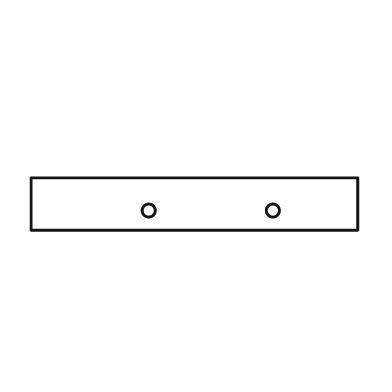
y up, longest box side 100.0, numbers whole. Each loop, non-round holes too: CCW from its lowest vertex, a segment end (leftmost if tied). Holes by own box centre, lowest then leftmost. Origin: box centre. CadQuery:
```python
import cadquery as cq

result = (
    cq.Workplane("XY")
    .moveTo(-50.0, -8.0)
    .lineTo(50.0, -8.0)
    .lineTo(50.0, 8.0)
    .lineTo(-50.0, 8.0)
    .close()
    .moveTo(-14.0, -2.0)
    .circle(2.0)
    .moveTo(24.0, -2.0)
    .circle(2.0)
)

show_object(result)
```